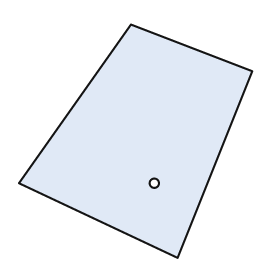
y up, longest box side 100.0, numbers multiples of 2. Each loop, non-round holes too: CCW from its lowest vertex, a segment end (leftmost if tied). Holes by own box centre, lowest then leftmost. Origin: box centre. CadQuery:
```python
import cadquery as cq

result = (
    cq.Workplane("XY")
    .moveTo(18.0, -50.0)
    .lineTo(50.0, 30.0)
    .lineTo(-2.0, 50.0)
    .lineTo(-50.0, -18.0)
    .close()
    .moveTo(8.0, -18.0)
    .circle(2.0)
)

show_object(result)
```